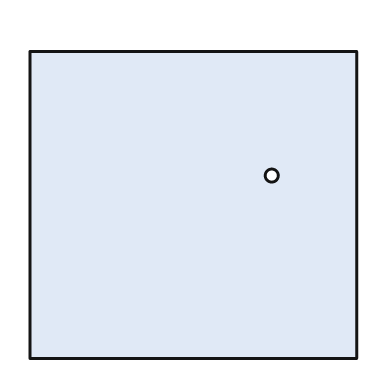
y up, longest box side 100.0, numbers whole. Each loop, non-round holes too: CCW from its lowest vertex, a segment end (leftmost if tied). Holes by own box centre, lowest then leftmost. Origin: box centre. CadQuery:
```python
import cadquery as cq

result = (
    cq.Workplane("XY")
    .moveTo(-50.0, -47.0)
    .lineTo(50.0, -47.0)
    .lineTo(50.0, 47.0)
    .lineTo(-50.0, 47.0)
    .close()
    .moveTo(24.0, 9.0)
    .circle(2.0)
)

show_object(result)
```